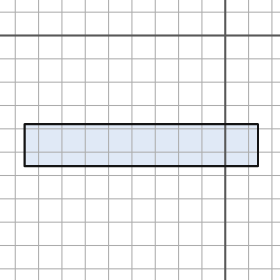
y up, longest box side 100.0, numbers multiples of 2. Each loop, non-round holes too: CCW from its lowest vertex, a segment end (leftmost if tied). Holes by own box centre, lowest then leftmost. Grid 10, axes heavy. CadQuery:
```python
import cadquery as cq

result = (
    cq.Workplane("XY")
    .moveTo(-86.0, -56.0)
    .lineTo(14.0, -56.0)
    .lineTo(14.0, -38.0)
    .lineTo(-86.0, -38.0)
    .close()
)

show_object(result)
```